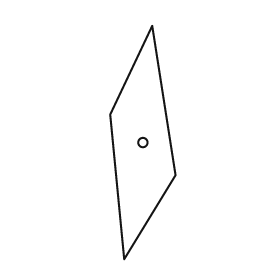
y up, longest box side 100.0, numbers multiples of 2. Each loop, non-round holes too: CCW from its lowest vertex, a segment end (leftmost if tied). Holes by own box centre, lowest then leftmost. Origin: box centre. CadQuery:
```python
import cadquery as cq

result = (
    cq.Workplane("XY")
    .moveTo(-8.0, -50.0)
    .lineTo(14.0, -14.0)
    .lineTo(4.0, 50.0)
    .lineTo(-14.0, 12.0)
    .close()
    .moveTo(0.0, 0.0)
    .circle(2.0)
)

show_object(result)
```